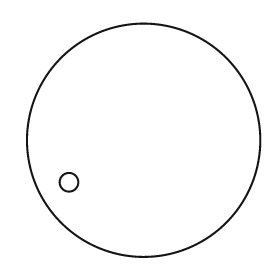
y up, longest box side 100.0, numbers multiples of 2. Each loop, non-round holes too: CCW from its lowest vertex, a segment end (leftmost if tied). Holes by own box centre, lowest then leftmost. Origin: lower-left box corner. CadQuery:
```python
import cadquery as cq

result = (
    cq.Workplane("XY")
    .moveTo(50.0, 50.0)
    .circle(50.0)
    .moveTo(18.0, 32.0)
    .circle(4.0)
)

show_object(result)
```